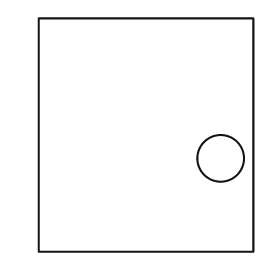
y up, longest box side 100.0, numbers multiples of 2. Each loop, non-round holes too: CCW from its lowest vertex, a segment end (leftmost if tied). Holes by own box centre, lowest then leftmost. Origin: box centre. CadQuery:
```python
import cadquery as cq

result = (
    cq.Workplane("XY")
    .moveTo(-46.0, -50.0)
    .lineTo(46.0, -50.0)
    .lineTo(46.0, 50.0)
    .lineTo(-46.0, 50.0)
    .close()
    .moveTo(32.0, -10.0)
    .circle(10.0)
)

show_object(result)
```